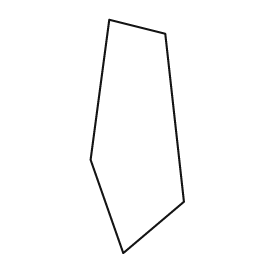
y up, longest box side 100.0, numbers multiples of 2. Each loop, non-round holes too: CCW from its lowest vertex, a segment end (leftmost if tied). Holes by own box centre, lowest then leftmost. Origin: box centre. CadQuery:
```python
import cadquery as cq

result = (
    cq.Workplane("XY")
    .moveTo(-6.0, -50.0)
    .lineTo(20.0, -28.0)
    .lineTo(12.0, 44.0)
    .lineTo(-12.0, 50.0)
    .lineTo(-20.0, -10.0)
    .close()
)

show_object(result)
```